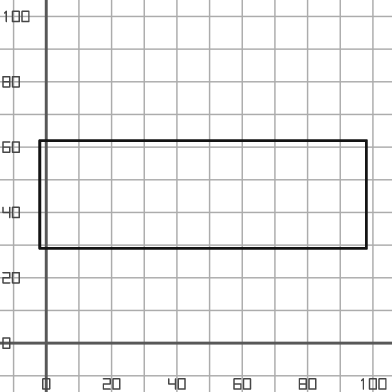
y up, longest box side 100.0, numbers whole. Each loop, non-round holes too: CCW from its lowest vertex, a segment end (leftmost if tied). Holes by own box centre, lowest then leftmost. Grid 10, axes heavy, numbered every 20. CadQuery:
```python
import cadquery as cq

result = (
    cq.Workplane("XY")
    .moveTo(-2.0, 29.0)
    .lineTo(98.0, 29.0)
    .lineTo(98.0, 62.0)
    .lineTo(-2.0, 62.0)
    .close()
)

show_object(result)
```